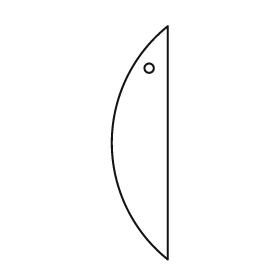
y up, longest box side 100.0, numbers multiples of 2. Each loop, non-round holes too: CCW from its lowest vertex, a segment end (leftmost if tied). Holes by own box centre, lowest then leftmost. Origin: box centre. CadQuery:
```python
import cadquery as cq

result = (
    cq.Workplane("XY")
    .moveTo(12.0, -50.0)
    .lineTo(12.0, 50.0)
    .threePointArc((-12.0, 0.0), (12.0, -50.0))
    .close()
    .moveTo(4.0, 32.0)
    .circle(2.0)
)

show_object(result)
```